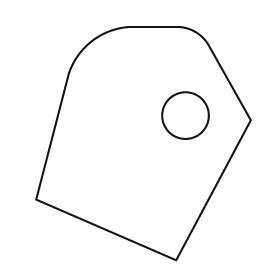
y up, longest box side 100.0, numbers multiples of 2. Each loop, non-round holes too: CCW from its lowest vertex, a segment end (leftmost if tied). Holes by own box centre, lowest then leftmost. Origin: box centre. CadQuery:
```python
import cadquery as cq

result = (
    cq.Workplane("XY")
    .moveTo(14.0, -50.0)
    .lineTo(46.0, 10.0)
    .lineTo(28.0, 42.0)
    .threePointArc((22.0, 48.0), (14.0, 50.0))
    .lineTo(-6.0, 50.0)
    .threePointArc((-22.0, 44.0), (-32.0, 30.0))
    .lineTo(-46.0, -24.0)
    .close()
    .moveTo(18.0, 12.0)
    .circle(10.0)
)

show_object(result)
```